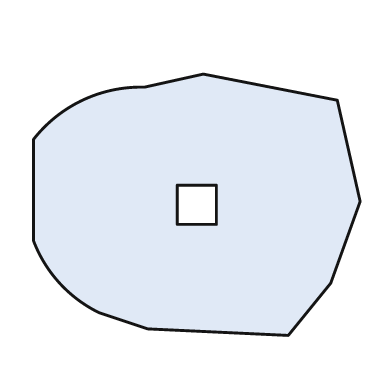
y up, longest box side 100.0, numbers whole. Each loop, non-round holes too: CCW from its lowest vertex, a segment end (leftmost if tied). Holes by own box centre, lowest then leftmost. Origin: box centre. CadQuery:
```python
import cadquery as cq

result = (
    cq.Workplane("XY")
    .moveTo(28.0, -40.0)
    .lineTo(41.0, -24.0)
    .lineTo(50.0, 1.0)
    .lineTo(43.0, 32.0)
    .lineTo(2.0, 40.0)
    .lineTo(-16.0, 36.0)
    .threePointArc((-35.0, 32.0), (-50.0, 20.0))
    .lineTo(-50.0, -11.0)
    .threePointArc((-42.0, -24.0), (-30.0, -33.0))
    .lineTo(-15.0, -38.0)
    .close()
    .moveTo(-6.0, -6.0)
    .lineTo(6.0, -6.0)
    .lineTo(6.0, 6.0)
    .lineTo(-6.0, 6.0)
    .close()
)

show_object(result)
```